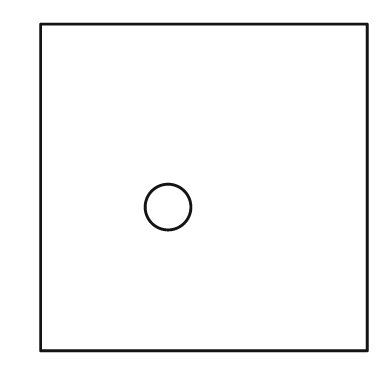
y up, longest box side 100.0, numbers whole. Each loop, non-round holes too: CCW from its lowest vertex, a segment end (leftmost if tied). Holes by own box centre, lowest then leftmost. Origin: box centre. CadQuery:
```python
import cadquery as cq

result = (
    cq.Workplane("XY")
    .moveTo(-50.0, -50.0)
    .lineTo(50.0, -50.0)
    .lineTo(50.0, 50.0)
    .lineTo(-50.0, 50.0)
    .close()
    .moveTo(-11.0, -6.0)
    .circle(7.0)
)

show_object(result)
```